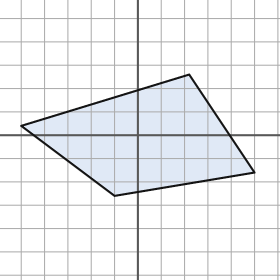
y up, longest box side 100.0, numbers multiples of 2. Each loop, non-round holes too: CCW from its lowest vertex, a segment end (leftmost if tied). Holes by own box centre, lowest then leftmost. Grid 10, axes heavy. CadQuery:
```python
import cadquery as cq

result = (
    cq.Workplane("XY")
    .moveTo(-10.0, -26.0)
    .lineTo(50.0, -16.0)
    .lineTo(22.0, 26.0)
    .lineTo(-50.0, 4.0)
    .close()
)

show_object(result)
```